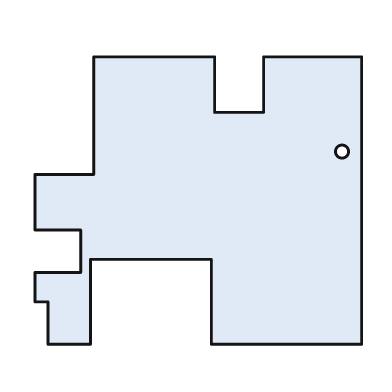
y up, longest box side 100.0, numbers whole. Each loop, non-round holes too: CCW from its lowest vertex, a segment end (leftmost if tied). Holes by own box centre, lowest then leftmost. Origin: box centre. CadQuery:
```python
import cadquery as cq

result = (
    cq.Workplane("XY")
    .moveTo(-46.0, -44.0)
    .lineTo(-33.0, -44.0)
    .lineTo(-33.0, -18.0)
    .lineTo(4.0, -18.0)
    .lineTo(4.0, -44.0)
    .lineTo(50.0, -44.0)
    .lineTo(50.0, 44.0)
    .lineTo(20.0, 44.0)
    .lineTo(20.0, 27.0)
    .lineTo(5.0, 27.0)
    .lineTo(5.0, 44.0)
    .lineTo(-32.0, 44.0)
    .lineTo(-32.0, 8.0)
    .lineTo(-50.0, 8.0)
    .lineTo(-50.0, -9.0)
    .lineTo(-36.0, -9.0)
    .lineTo(-36.0, -22.0)
    .lineTo(-50.0, -22.0)
    .lineTo(-50.0, -31.0)
    .lineTo(-46.0, -31.0)
    .close()
    .moveTo(44.0, 15.0)
    .circle(2.0)
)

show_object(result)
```